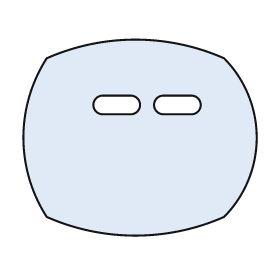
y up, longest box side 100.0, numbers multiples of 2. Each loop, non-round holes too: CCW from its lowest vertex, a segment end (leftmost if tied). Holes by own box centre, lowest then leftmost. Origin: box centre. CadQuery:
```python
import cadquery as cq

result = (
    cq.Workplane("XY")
    .moveTo(-40.0, -34.0)
    .threePointArc((-2.0, -42.0), (36.0, -34.0))
    .threePointArc((50.0, 0.0), (36.0, 34.0))
    .threePointArc((-2.0, 42.0), (-40.0, 34.0))
    .threePointArc((-50.0, 0.0), (-40.0, -34.0))
    .close()
    .moveTo(-16.0, 10.0)
    .lineTo(-4.0, 10.0)
    .threePointArc((0.0, 14.0), (-4.0, 18.0))
    .lineTo(-16.0, 18.0)
    .threePointArc((-20.0, 14.0), (-16.0, 10.0))
    .close()
    .moveTo(10.0, 10.0)
    .lineTo(22.0, 10.0)
    .threePointArc((26.0, 14.0), (22.0, 18.0))
    .lineTo(10.0, 18.0)
    .threePointArc((6.0, 14.0), (10.0, 10.0))
    .close()
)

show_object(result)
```